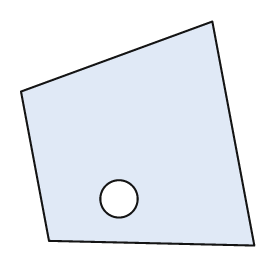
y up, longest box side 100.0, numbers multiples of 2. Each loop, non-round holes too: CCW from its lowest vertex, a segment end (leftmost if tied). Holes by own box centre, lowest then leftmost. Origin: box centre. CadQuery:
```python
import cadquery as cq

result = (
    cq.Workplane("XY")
    .moveTo(50.0, -48.0)
    .lineTo(32.0, 48.0)
    .lineTo(-50.0, 18.0)
    .lineTo(-38.0, -46.0)
    .close()
    .moveTo(-8.0, -28.0)
    .circle(8.0)
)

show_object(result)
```